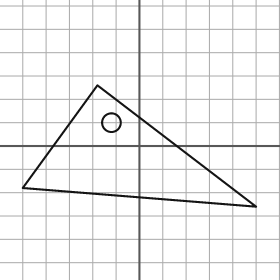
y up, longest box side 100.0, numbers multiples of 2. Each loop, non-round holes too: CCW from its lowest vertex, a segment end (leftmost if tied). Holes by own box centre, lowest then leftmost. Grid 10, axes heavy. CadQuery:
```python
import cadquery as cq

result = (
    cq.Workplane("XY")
    .moveTo(50.0, -26.0)
    .lineTo(-18.0, 26.0)
    .lineTo(-50.0, -18.0)
    .close()
    .moveTo(-12.0, 10.0)
    .circle(4.0)
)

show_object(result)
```